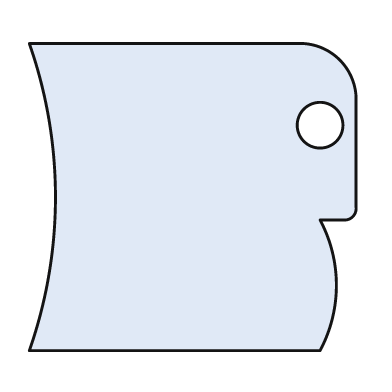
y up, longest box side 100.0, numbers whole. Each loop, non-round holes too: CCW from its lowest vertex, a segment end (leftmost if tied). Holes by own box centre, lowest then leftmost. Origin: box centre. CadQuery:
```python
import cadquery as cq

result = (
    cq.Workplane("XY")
    .moveTo(-50.0, -47.0)
    .lineTo(39.0, -47.0)
    .threePointArc((44.0, -27.0), (39.0, -7.0))
    .lineTo(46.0, -7.0)
    .threePointArc((49.0, -6.0), (50.0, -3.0))
    .lineTo(50.0, 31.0)
    .threePointArc((45.0, 42.0), (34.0, 47.0))
    .lineTo(-50.0, 47.0)
    .threePointArc((-42.0, 0.0), (-50.0, -47.0))
    .close()
    .moveTo(39.0, 22.0)
    .circle(7.0)
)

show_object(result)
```